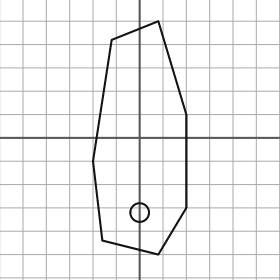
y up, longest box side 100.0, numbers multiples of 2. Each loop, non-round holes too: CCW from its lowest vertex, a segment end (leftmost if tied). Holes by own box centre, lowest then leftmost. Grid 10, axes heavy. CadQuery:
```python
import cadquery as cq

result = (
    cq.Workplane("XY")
    .moveTo(8.0, -50.0)
    .lineTo(20.0, -30.0)
    .lineTo(20.0, 10.0)
    .lineTo(8.0, 50.0)
    .lineTo(-12.0, 42.0)
    .lineTo(-20.0, -10.0)
    .lineTo(-16.0, -44.0)
    .close()
    .moveTo(0.0, -32.0)
    .circle(4.0)
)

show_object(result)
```